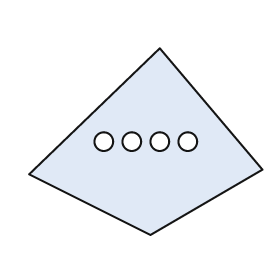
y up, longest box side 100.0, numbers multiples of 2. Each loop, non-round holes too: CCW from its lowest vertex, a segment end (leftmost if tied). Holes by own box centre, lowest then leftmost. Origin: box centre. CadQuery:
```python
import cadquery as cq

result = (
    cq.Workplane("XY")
    .moveTo(2.0, -40.0)
    .lineTo(50.0, -12.0)
    .lineTo(6.0, 40.0)
    .lineTo(-50.0, -14.0)
    .close()
    .moveTo(-18.0, 0.0)
    .circle(4.0)
    .moveTo(-6.0, 0.0)
    .circle(4.0)
    .moveTo(6.0, 0.0)
    .circle(4.0)
    .moveTo(18.0, 0.0)
    .circle(4.0)
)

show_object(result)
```